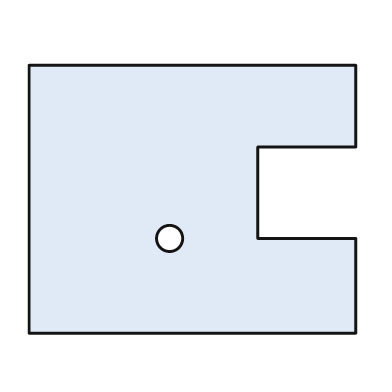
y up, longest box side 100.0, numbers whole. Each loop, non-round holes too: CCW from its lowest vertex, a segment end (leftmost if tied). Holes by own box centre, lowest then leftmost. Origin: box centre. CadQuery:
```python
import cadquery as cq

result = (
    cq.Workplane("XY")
    .moveTo(-50.0, -41.0)
    .lineTo(50.0, -41.0)
    .lineTo(50.0, -12.0)
    .lineTo(20.0, -12.0)
    .lineTo(20.0, 16.0)
    .lineTo(50.0, 16.0)
    .lineTo(50.0, 41.0)
    .lineTo(-50.0, 41.0)
    .close()
    .moveTo(-7.0, -12.0)
    .circle(4.0)
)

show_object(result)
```